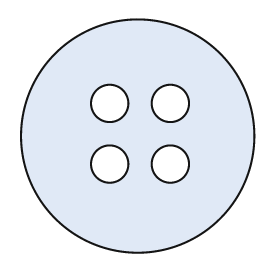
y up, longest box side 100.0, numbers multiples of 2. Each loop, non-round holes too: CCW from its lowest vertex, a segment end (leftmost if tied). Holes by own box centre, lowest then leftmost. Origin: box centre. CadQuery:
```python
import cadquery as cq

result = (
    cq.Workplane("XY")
    .moveTo(0.0, 0.0)
    .circle(50.0)
    .moveTo(-12.0, -12.0)
    .circle(8.0)
    .moveTo(14.0, -12.0)
    .circle(8.0)
    .moveTo(-12.0, 14.0)
    .circle(8.0)
    .moveTo(14.0, 14.0)
    .circle(8.0)
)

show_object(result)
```